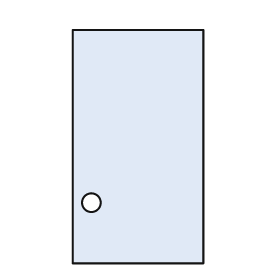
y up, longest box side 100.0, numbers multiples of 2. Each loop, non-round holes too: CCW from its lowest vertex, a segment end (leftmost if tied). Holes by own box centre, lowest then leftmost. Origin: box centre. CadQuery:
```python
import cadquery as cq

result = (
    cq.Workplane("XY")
    .moveTo(-28.0, -50.0)
    .lineTo(28.0, -50.0)
    .lineTo(28.0, 50.0)
    .lineTo(-28.0, 50.0)
    .close()
    .moveTo(-20.0, -24.0)
    .circle(4.0)
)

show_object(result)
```